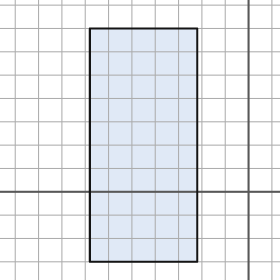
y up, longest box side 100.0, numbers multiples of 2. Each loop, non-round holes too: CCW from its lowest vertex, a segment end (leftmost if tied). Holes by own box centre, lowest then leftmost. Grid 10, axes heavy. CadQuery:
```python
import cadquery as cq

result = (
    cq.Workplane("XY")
    .moveTo(-68.0, -30.0)
    .lineTo(-22.0, -30.0)
    .lineTo(-22.0, 70.0)
    .lineTo(-68.0, 70.0)
    .close()
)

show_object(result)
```